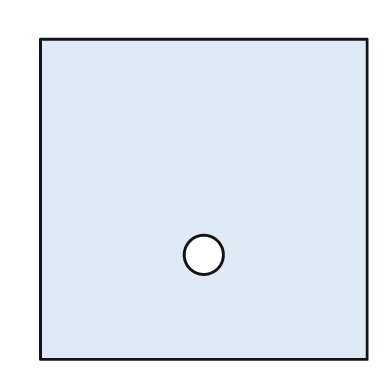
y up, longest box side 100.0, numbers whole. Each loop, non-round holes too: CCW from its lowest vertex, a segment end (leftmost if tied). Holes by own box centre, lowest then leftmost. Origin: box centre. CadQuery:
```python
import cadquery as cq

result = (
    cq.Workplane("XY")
    .moveTo(-50.0, -49.0)
    .lineTo(50.0, -49.0)
    .lineTo(50.0, 49.0)
    .lineTo(-50.0, 49.0)
    .close()
    .moveTo(0.0, -17.0)
    .circle(6.0)
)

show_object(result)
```